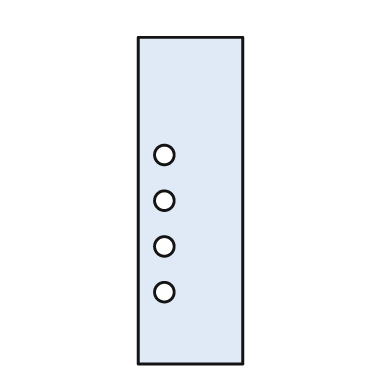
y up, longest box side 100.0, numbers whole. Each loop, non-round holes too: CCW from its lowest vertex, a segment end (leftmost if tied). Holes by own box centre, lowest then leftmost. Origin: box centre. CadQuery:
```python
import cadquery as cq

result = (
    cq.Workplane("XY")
    .moveTo(-16.0, -50.0)
    .lineTo(16.0, -50.0)
    .lineTo(16.0, 50.0)
    .lineTo(-16.0, 50.0)
    .close()
    .moveTo(-8.0, -28.0)
    .circle(3.0)
    .moveTo(-8.0, -14.0)
    .circle(3.0)
    .moveTo(-8.0, 0.0)
    .circle(3.0)
    .moveTo(-8.0, 14.0)
    .circle(3.0)
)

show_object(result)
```